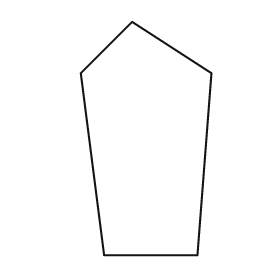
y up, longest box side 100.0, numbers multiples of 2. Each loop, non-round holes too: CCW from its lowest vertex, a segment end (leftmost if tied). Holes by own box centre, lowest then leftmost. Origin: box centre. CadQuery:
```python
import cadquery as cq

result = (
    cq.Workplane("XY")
    .moveTo(-18.0, -50.0)
    .lineTo(22.0, -50.0)
    .lineTo(28.0, 28.0)
    .lineTo(-6.0, 50.0)
    .lineTo(-28.0, 28.0)
    .close()
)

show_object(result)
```